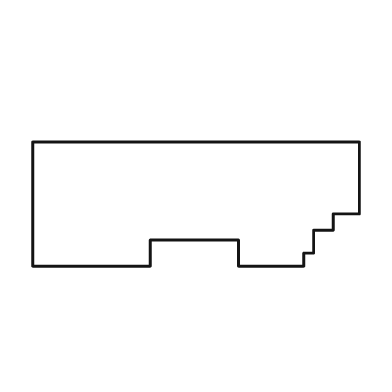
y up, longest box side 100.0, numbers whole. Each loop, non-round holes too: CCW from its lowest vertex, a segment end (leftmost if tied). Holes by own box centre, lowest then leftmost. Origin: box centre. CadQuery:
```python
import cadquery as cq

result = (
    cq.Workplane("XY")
    .moveTo(-50.0, -19.0)
    .lineTo(-14.0, -19.0)
    .lineTo(-14.0, -11.0)
    .lineTo(13.0, -11.0)
    .lineTo(13.0, -19.0)
    .lineTo(33.0, -19.0)
    .lineTo(33.0, -15.0)
    .lineTo(36.0, -15.0)
    .lineTo(36.0, -8.0)
    .lineTo(42.0, -8.0)
    .lineTo(42.0, -3.0)
    .lineTo(50.0, -3.0)
    .lineTo(50.0, 19.0)
    .lineTo(-50.0, 19.0)
    .close()
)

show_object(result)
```